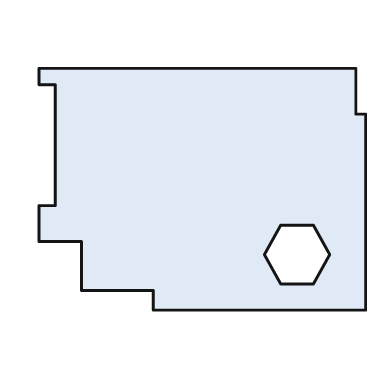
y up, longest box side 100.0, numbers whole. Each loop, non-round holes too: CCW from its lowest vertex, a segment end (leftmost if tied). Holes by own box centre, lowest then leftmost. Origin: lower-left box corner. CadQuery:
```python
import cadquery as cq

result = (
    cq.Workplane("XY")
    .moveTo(35.0, 0.0)
    .lineTo(100.0, 0.0)
    .lineTo(100.0, 60.0)
    .lineTo(97.0, 60.0)
    .lineTo(97.0, 74.0)
    .lineTo(0.0, 74.0)
    .lineTo(0.0, 69.0)
    .lineTo(5.0, 69.0)
    .lineTo(5.0, 32.0)
    .lineTo(0.0, 32.0)
    .lineTo(0.0, 21.0)
    .lineTo(13.0, 21.0)
    .lineTo(13.0, 6.0)
    .lineTo(35.0, 6.0)
    .close()
    .moveTo(74.0, 8.0)
    .lineTo(84.0, 8.0)
    .lineTo(89.0, 17.0)
    .lineTo(84.0, 26.0)
    .lineTo(74.0, 26.0)
    .lineTo(69.0, 17.0)
    .close()
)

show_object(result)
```